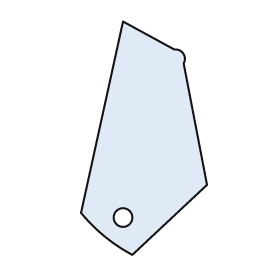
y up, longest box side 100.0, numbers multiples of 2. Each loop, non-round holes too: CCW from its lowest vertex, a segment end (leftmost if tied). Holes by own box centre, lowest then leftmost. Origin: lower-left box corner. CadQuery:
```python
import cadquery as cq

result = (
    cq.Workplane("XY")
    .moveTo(22.0, 0.0)
    .lineTo(54.0, 30.0)
    .lineTo(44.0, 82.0)
    .threePointArc((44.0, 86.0), (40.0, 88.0))
    .lineTo(18.0, 100.0)
    .lineTo(0.0, 18.0)
    .threePointArc((10.0, 8.0), (22.0, 0.0))
    .close()
    .moveTo(18.0, 16.0)
    .circle(4.0)
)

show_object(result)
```